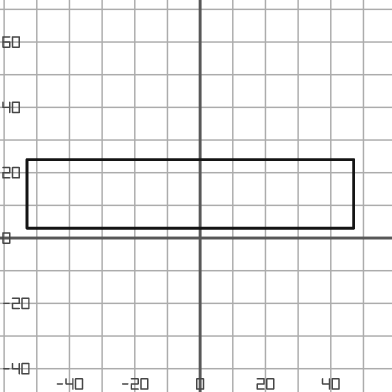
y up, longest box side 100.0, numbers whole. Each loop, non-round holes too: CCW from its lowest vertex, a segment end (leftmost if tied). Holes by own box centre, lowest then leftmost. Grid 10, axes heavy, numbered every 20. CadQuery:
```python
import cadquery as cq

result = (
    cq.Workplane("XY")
    .moveTo(-53.0, 3.0)
    .lineTo(47.0, 3.0)
    .lineTo(47.0, 24.0)
    .lineTo(-53.0, 24.0)
    .close()
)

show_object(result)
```